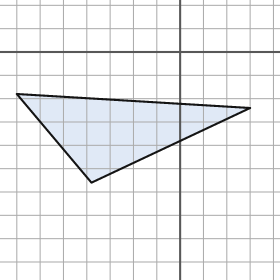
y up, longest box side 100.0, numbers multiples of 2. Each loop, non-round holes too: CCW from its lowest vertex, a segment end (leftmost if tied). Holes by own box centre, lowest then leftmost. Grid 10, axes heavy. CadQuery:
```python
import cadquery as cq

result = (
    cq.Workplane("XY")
    .moveTo(-38.0, -56.0)
    .lineTo(30.0, -24.0)
    .lineTo(-70.0, -18.0)
    .close()
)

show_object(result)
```